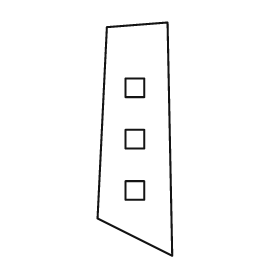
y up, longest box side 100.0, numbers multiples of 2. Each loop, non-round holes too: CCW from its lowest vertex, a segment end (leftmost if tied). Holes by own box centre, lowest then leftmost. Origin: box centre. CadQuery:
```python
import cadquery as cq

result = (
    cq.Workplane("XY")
    .moveTo(16.0, -50.0)
    .lineTo(14.0, 50.0)
    .lineTo(-12.0, 48.0)
    .lineTo(-16.0, -34.0)
    .close()
    .moveTo(-4.0, -26.0)
    .lineTo(4.0, -26.0)
    .lineTo(4.0, -18.0)
    .lineTo(-4.0, -18.0)
    .close()
    .moveTo(-4.0, -4.0)
    .lineTo(4.0, -4.0)
    .lineTo(4.0, 4.0)
    .lineTo(-4.0, 4.0)
    .close()
    .moveTo(-4.0, 18.0)
    .lineTo(4.0, 18.0)
    .lineTo(4.0, 26.0)
    .lineTo(-4.0, 26.0)
    .close()
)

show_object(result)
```